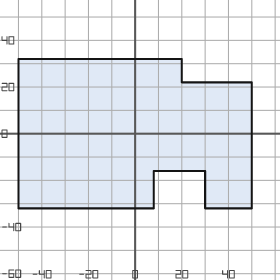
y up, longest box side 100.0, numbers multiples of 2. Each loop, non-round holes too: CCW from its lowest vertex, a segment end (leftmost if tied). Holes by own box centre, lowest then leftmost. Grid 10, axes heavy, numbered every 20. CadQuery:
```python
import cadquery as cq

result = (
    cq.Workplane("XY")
    .moveTo(-50.0, -32.0)
    .lineTo(8.0, -32.0)
    .lineTo(8.0, -16.0)
    .lineTo(30.0, -16.0)
    .lineTo(30.0, -32.0)
    .lineTo(50.0, -32.0)
    .lineTo(50.0, 22.0)
    .lineTo(20.0, 22.0)
    .lineTo(20.0, 32.0)
    .lineTo(-50.0, 32.0)
    .close()
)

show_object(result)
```